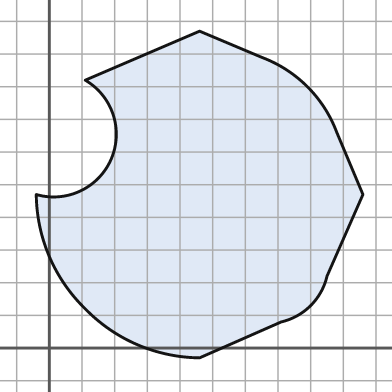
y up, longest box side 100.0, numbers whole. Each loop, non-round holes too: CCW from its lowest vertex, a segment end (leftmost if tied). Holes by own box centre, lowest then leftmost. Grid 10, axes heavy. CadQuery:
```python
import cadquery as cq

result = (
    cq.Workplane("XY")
    .moveTo(46.0, -3.0)
    .lineTo(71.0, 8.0)
    .threePointArc((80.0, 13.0), (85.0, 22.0))
    .lineTo(96.0, 47.0)
    .lineTo(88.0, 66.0)
    .threePointArc((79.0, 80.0), (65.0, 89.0))
    .lineTo(46.0, 97.0)
    .lineTo(11.0, 82.0)
    .threePointArc((19.0, 58.0), (-4.0, 47.0))
    .threePointArc((0.0, 28.0), (11.0, 12.0))
    .threePointArc((27.0, 1.0), (46.0, -3.0))
    .close()
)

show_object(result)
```